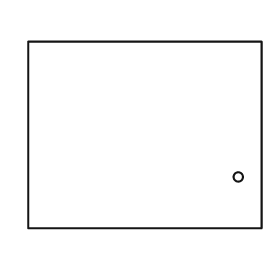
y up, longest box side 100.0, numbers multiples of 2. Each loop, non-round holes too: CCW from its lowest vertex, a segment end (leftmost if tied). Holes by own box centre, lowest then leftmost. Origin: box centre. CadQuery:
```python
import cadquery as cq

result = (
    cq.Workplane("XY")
    .moveTo(-50.0, -40.0)
    .lineTo(50.0, -40.0)
    .lineTo(50.0, 40.0)
    .lineTo(-50.0, 40.0)
    .close()
    .moveTo(40.0, -18.0)
    .circle(2.0)
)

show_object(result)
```